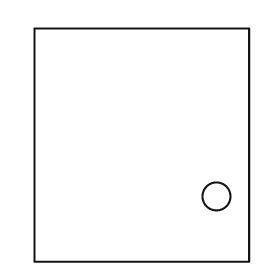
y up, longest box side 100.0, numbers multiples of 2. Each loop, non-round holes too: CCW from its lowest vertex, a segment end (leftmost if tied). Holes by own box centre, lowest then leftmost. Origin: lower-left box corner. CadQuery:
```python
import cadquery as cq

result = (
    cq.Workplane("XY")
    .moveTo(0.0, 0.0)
    .lineTo(92.0, 0.0)
    .lineTo(92.0, 100.0)
    .lineTo(0.0, 100.0)
    .close()
    .moveTo(78.0, 28.0)
    .circle(6.0)
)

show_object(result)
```